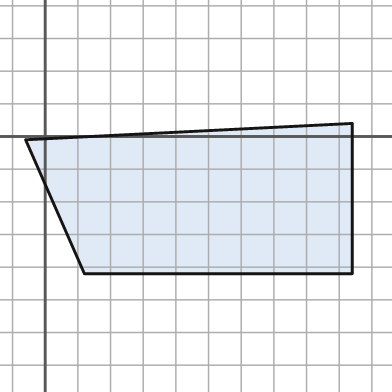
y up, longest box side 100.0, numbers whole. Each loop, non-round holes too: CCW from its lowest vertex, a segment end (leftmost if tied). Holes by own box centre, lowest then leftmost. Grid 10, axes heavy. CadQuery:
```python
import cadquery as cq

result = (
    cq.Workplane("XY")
    .moveTo(12.0, -42.0)
    .lineTo(94.0, -42.0)
    .lineTo(94.0, 4.0)
    .lineTo(-6.0, -1.0)
    .close()
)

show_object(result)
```